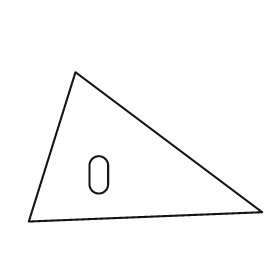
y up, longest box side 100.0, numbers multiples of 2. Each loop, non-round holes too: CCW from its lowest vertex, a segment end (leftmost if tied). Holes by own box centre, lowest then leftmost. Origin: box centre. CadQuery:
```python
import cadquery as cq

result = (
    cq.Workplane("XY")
    .moveTo(-50.0, -32.0)
    .lineTo(50.0, -28.0)
    .lineTo(-30.0, 32.0)
    .close()
    .moveTo(-24.0, -16.0)
    .threePointArc((-20.0, -20.0), (-16.0, -16.0))
    .lineTo(-16.0, -8.0)
    .threePointArc((-20.0, -4.0), (-24.0, -8.0))
    .close()
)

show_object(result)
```